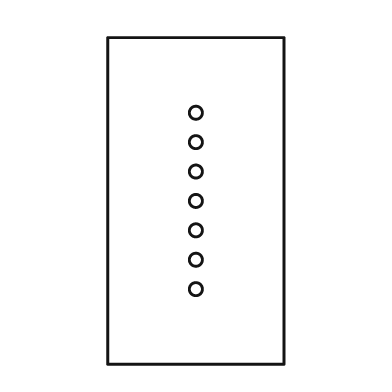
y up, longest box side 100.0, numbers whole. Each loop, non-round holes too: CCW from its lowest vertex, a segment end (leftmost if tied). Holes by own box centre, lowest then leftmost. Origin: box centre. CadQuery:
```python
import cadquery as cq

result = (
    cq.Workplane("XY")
    .moveTo(-27.0, -50.0)
    .lineTo(27.0, -50.0)
    .lineTo(27.0, 50.0)
    .lineTo(-27.0, 50.0)
    .close()
    .moveTo(0.0, -27.0)
    .circle(2.0)
    .moveTo(0.0, -18.0)
    .circle(2.0)
    .moveTo(0.0, -9.0)
    .circle(2.0)
    .moveTo(0.0, 0.0)
    .circle(2.0)
    .moveTo(0.0, 9.0)
    .circle(2.0)
    .moveTo(0.0, 18.0)
    .circle(2.0)
    .moveTo(0.0, 27.0)
    .circle(2.0)
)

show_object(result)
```